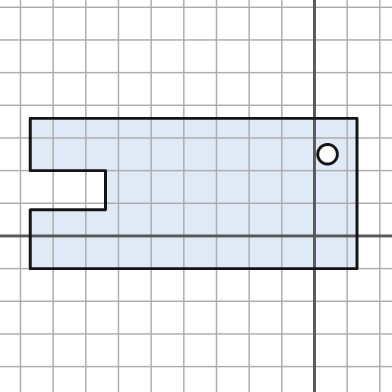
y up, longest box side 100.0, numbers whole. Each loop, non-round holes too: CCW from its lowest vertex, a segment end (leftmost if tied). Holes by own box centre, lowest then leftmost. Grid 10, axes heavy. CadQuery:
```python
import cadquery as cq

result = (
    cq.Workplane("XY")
    .moveTo(-87.0, -10.0)
    .lineTo(13.0, -10.0)
    .lineTo(13.0, 36.0)
    .lineTo(-87.0, 36.0)
    .lineTo(-87.0, 20.0)
    .lineTo(-64.0, 20.0)
    .lineTo(-64.0, 8.0)
    .lineTo(-87.0, 8.0)
    .close()
    .moveTo(4.0, 25.0)
    .circle(3.0)
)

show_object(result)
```